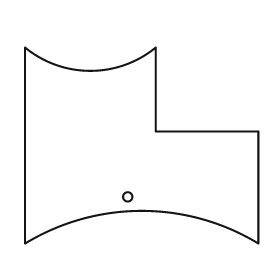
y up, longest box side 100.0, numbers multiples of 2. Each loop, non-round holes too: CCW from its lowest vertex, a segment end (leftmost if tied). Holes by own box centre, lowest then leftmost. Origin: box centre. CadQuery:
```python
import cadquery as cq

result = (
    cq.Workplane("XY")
    .moveTo(-50.0, -42.0)
    .threePointArc((0.0, -28.0), (50.0, -42.0))
    .lineTo(50.0, 6.0)
    .lineTo(6.0, 6.0)
    .lineTo(6.0, 42.0)
    .threePointArc((-22.0, 32.0), (-50.0, 42.0))
    .close()
    .moveTo(-6.0, -22.0)
    .circle(2.0)
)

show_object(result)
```